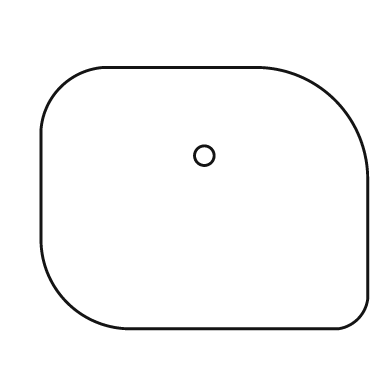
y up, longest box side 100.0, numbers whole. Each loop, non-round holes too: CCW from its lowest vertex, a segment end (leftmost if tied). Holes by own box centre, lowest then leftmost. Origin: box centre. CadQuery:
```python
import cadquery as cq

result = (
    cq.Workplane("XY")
    .moveTo(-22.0, -40.0)
    .lineTo(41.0, -40.0)
    .threePointArc((47.0, -37.0), (50.0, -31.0))
    .lineTo(50.0, 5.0)
    .threePointArc((40.0, 30.0), (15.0, 40.0))
    .lineTo(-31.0, 40.0)
    .threePointArc((-44.0, 34.0), (-50.0, 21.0))
    .lineTo(-50.0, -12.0)
    .threePointArc((-42.0, -32.0), (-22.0, -40.0))
    .close()
    .moveTo(0.0, 13.0)
    .circle(3.0)
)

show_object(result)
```